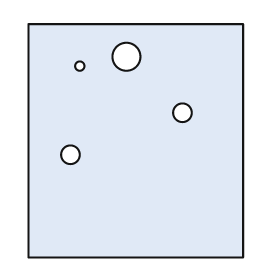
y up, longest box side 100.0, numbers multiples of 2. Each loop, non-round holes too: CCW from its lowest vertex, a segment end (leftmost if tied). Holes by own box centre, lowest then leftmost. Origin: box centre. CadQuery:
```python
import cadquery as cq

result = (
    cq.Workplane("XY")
    .moveTo(-46.0, -50.0)
    .lineTo(46.0, -50.0)
    .lineTo(46.0, 50.0)
    .lineTo(-46.0, 50.0)
    .close()
    .moveTo(-28.0, -6.0)
    .circle(4.0)
    .moveTo(20.0, 12.0)
    .circle(4.0)
    .moveTo(-24.0, 32.0)
    .circle(2.0)
    .moveTo(-4.0, 36.0)
    .circle(6.0)
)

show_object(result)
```